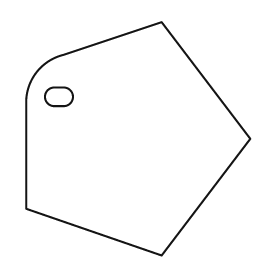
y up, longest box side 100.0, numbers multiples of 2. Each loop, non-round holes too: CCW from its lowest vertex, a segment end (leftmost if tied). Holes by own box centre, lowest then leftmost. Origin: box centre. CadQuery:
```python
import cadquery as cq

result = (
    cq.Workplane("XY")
    .moveTo(10.0, -50.0)
    .lineTo(48.0, 0.0)
    .lineTo(10.0, 50.0)
    .lineTo(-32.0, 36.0)
    .threePointArc((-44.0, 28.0), (-48.0, 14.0))
    .lineTo(-48.0, -30.0)
    .close()
    .moveTo(-36.0, 14.0)
    .lineTo(-32.0, 14.0)
    .threePointArc((-28.0, 18.0), (-32.0, 22.0))
    .lineTo(-36.0, 22.0)
    .threePointArc((-40.0, 18.0), (-36.0, 14.0))
    .close()
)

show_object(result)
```